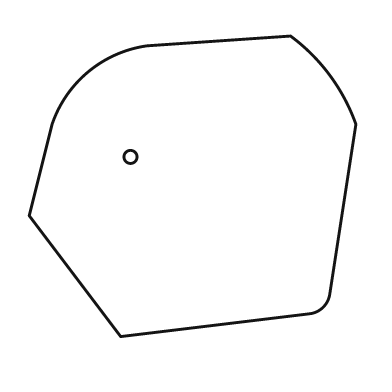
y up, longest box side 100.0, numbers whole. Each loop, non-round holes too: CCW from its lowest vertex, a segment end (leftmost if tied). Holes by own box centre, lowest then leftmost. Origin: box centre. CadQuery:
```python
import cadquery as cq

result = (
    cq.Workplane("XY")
    .moveTo(-22.0, -46.0)
    .lineTo(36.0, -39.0)
    .threePointArc((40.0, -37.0), (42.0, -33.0))
    .lineTo(50.0, 19.0)
    .threePointArc((42.0, 34.0), (30.0, 46.0))
    .lineTo(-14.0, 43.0)
    .threePointArc((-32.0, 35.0), (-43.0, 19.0))
    .lineTo(-50.0, -9.0)
    .close()
    .moveTo(-19.0, 9.0)
    .circle(2.0)
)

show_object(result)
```